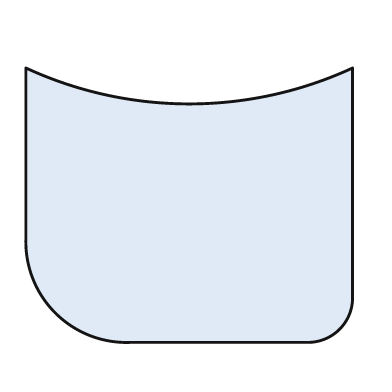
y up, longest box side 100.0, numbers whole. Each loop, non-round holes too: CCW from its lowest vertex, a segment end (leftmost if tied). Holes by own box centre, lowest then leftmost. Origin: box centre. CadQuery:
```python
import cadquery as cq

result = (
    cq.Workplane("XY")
    .moveTo(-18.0, -42.0)
    .lineTo(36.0, -42.0)
    .threePointArc((46.0, -38.0), (50.0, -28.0))
    .lineTo(50.0, 42.0)
    .threePointArc((0.0, 31.0), (-50.0, 42.0))
    .lineTo(-50.0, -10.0)
    .threePointArc((-41.0, -33.0), (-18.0, -42.0))
    .close()
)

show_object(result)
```